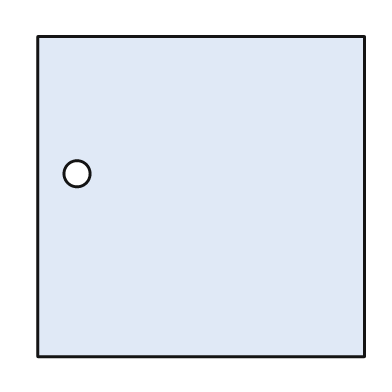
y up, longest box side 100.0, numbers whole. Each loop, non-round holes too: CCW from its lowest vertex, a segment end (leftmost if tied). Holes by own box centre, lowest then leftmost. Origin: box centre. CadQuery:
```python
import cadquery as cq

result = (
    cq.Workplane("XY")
    .moveTo(-50.0, -49.0)
    .lineTo(50.0, -49.0)
    .lineTo(50.0, 49.0)
    .lineTo(-50.0, 49.0)
    .close()
    .moveTo(-38.0, 7.0)
    .circle(4.0)
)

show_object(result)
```